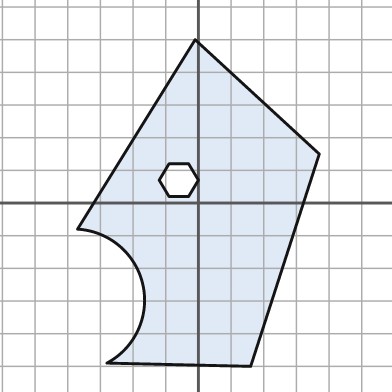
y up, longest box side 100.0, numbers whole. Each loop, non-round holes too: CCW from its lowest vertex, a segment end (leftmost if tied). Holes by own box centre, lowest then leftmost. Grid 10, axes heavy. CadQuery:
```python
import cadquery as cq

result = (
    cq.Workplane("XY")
    .moveTo(16.0, -50.0)
    .lineTo(37.0, 15.0)
    .lineTo(-1.0, 50.0)
    .lineTo(-37.0, -8.0)
    .threePointArc((-17.0, -25.0), (-28.0, -49.0))
    .close()
    .moveTo(-9.0, 2.0)
    .lineTo(-3.0, 2.0)
    .lineTo(0.0, 7.0)
    .lineTo(-3.0, 12.0)
    .lineTo(-9.0, 12.0)
    .lineTo(-12.0, 7.0)
    .close()
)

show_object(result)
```